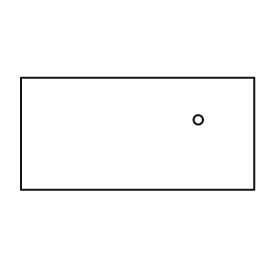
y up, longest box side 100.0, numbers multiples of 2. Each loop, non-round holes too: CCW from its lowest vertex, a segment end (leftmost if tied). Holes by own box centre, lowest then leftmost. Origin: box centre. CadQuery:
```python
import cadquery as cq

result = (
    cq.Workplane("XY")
    .moveTo(-50.0, -24.0)
    .lineTo(50.0, -24.0)
    .lineTo(50.0, 24.0)
    .lineTo(-50.0, 24.0)
    .close()
    .moveTo(26.0, 6.0)
    .circle(2.0)
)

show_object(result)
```